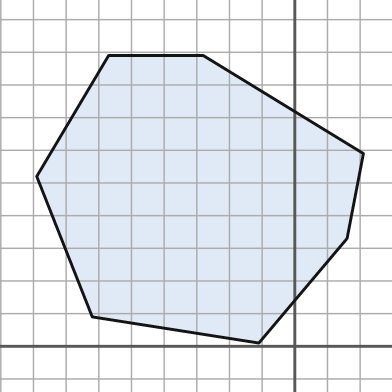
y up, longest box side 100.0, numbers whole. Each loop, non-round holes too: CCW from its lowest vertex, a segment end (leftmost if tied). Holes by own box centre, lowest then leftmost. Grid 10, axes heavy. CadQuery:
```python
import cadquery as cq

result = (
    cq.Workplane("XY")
    .moveTo(-11.0, 1.0)
    .lineTo(16.0, 33.0)
    .lineTo(21.0, 59.0)
    .lineTo(-28.0, 89.0)
    .lineTo(-57.0, 89.0)
    .lineTo(-79.0, 52.0)
    .lineTo(-62.0, 9.0)
    .close()
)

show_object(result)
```